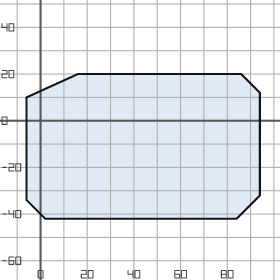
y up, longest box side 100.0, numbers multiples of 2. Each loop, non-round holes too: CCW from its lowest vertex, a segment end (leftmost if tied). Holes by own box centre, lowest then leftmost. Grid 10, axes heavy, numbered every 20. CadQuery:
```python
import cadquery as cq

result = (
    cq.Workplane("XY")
    .moveTo(2.0, -42.0)
    .lineTo(84.0, -42.0)
    .lineTo(94.0, -32.0)
    .lineTo(94.0, 12.0)
    .lineTo(86.0, 20.0)
    .lineTo(16.0, 20.0)
    .lineTo(-6.0, 10.0)
    .lineTo(-6.0, -34.0)
    .close()
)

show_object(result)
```